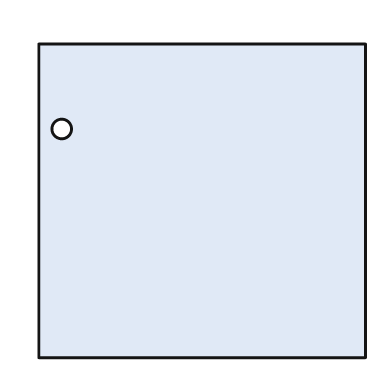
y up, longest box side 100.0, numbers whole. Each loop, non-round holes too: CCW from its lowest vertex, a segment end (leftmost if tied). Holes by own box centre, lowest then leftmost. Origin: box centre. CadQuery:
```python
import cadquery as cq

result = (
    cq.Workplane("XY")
    .moveTo(-50.0, -48.0)
    .lineTo(50.0, -48.0)
    .lineTo(50.0, 48.0)
    .lineTo(-50.0, 48.0)
    .close()
    .moveTo(-43.0, 22.0)
    .circle(3.0)
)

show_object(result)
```